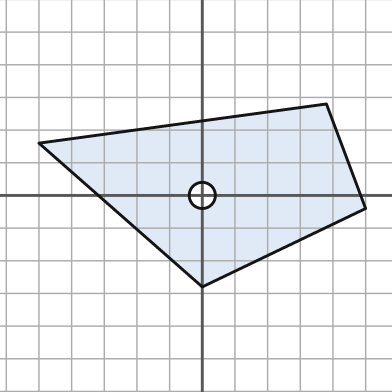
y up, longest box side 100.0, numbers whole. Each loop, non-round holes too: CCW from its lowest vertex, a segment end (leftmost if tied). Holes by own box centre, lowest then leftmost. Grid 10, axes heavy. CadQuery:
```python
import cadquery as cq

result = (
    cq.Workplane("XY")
    .moveTo(0.0, -28.0)
    .lineTo(50.0, -4.0)
    .lineTo(38.0, 28.0)
    .lineTo(-50.0, 16.0)
    .close()
    .moveTo(0.0, 0.0)
    .circle(4.0)
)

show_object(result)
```